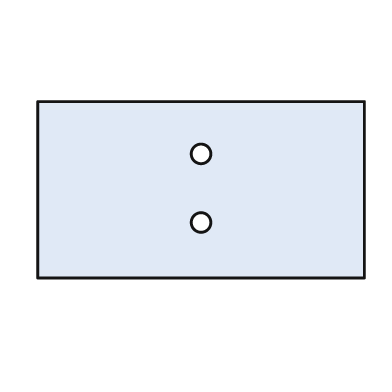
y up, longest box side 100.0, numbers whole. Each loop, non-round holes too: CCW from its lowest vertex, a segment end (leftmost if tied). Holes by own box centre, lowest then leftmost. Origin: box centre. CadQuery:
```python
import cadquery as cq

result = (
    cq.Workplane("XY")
    .moveTo(-50.0, -27.0)
    .lineTo(50.0, -27.0)
    .lineTo(50.0, 27.0)
    .lineTo(-50.0, 27.0)
    .close()
    .moveTo(0.0, -10.0)
    .circle(3.0)
    .moveTo(0.0, 11.0)
    .circle(3.0)
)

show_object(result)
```